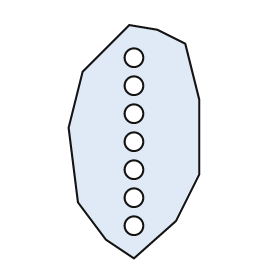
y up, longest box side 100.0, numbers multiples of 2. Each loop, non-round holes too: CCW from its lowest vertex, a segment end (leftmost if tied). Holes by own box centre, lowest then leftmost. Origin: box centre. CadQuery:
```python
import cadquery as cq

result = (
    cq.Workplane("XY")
    .moveTo(0.0, -50.0)
    .lineTo(18.0, -34.0)
    .lineTo(28.0, -14.0)
    .lineTo(28.0, 18.0)
    .lineTo(22.0, 42.0)
    .lineTo(10.0, 48.0)
    .lineTo(-2.0, 50.0)
    .lineTo(-22.0, 30.0)
    .lineTo(-28.0, 6.0)
    .lineTo(-24.0, -26.0)
    .lineTo(-12.0, -42.0)
    .close()
    .moveTo(0.0, -36.0)
    .circle(4.0)
    .moveTo(0.0, -24.0)
    .circle(4.0)
    .moveTo(0.0, -12.0)
    .circle(4.0)
    .moveTo(0.0, 0.0)
    .circle(4.0)
    .moveTo(0.0, 12.0)
    .circle(4.0)
    .moveTo(0.0, 24.0)
    .circle(4.0)
    .moveTo(0.0, 36.0)
    .circle(4.0)
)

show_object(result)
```